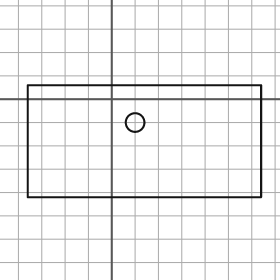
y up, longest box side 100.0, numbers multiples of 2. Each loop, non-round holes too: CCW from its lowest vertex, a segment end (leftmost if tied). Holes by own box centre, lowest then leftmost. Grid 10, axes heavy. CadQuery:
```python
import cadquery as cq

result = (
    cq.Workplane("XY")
    .moveTo(-36.0, -42.0)
    .lineTo(64.0, -42.0)
    .lineTo(64.0, 6.0)
    .lineTo(-36.0, 6.0)
    .close()
    .moveTo(10.0, -10.0)
    .circle(4.0)
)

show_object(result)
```